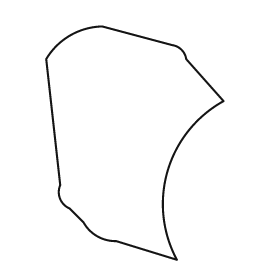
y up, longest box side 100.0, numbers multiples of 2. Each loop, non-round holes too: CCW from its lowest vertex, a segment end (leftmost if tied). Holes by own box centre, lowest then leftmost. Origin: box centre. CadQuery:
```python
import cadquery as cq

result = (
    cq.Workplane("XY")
    .moveTo(18.0, -50.0)
    .threePointArc((14.0, -12.0), (38.0, 18.0))
    .lineTo(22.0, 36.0)
    .threePointArc((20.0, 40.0), (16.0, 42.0))
    .lineTo(-14.0, 50.0)
    .threePointArc((-28.0, 46.0), (-38.0, 36.0))
    .lineTo(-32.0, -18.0)
    .threePointArc((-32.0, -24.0), (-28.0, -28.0))
    .lineTo(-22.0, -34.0)
    .threePointArc((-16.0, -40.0), (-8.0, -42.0))
    .close()
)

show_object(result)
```